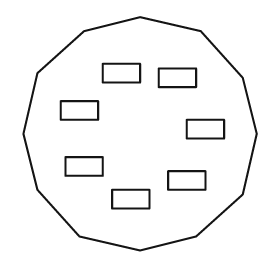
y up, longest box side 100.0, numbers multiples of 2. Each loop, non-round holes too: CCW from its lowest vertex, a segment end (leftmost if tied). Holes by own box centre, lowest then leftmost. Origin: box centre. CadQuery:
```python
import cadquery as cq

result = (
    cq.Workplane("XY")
    .moveTo(0.0, -50.0)
    .lineTo(24.0, -44.0)
    .lineTo(44.0, -26.0)
    .lineTo(50.0, 0.0)
    .lineTo(44.0, 24.0)
    .lineTo(26.0, 44.0)
    .lineTo(0.0, 50.0)
    .lineTo(-24.0, 44.0)
    .lineTo(-44.0, 26.0)
    .lineTo(-50.0, 0.0)
    .lineTo(-44.0, -24.0)
    .lineTo(-26.0, -44.0)
    .close()
    .moveTo(-12.0, -32.0)
    .lineTo(4.0, -32.0)
    .lineTo(4.0, -24.0)
    .lineTo(-12.0, -24.0)
    .close()
    .moveTo(12.0, -24.0)
    .lineTo(28.0, -24.0)
    .lineTo(28.0, -16.0)
    .lineTo(12.0, -16.0)
    .close()
    .moveTo(-32.0, -18.0)
    .lineTo(-16.0, -18.0)
    .lineTo(-16.0, -10.0)
    .lineTo(-32.0, -10.0)
    .close()
    .moveTo(20.0, -2.0)
    .lineTo(36.0, -2.0)
    .lineTo(36.0, 6.0)
    .lineTo(20.0, 6.0)
    .close()
    .moveTo(-34.0, 6.0)
    .lineTo(-18.0, 6.0)
    .lineTo(-18.0, 14.0)
    .lineTo(-34.0, 14.0)
    .close()
    .moveTo(8.0, 20.0)
    .lineTo(24.0, 20.0)
    .lineTo(24.0, 28.0)
    .lineTo(8.0, 28.0)
    .close()
    .moveTo(-16.0, 22.0)
    .lineTo(0.0, 22.0)
    .lineTo(0.0, 30.0)
    .lineTo(-16.0, 30.0)
    .close()
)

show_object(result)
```